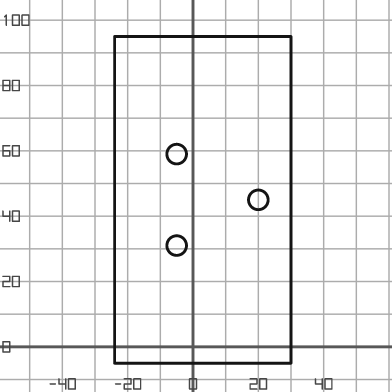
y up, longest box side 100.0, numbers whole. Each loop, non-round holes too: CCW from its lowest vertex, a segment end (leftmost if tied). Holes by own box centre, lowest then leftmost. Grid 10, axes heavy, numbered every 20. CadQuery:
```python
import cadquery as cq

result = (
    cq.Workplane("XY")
    .moveTo(-24.0, -5.0)
    .lineTo(30.0, -5.0)
    .lineTo(30.0, 95.0)
    .lineTo(-24.0, 95.0)
    .close()
    .moveTo(-5.0, 31.0)
    .circle(3.0)
    .moveTo(20.0, 45.0)
    .circle(3.0)
    .moveTo(-5.0, 59.0)
    .circle(3.0)
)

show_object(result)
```